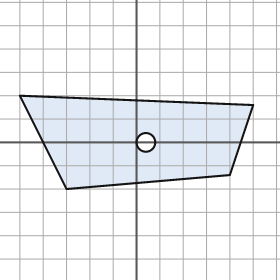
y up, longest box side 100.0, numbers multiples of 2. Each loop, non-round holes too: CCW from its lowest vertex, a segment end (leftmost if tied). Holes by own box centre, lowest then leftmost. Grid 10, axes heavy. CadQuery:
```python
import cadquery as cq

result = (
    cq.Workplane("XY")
    .moveTo(-30.0, -20.0)
    .lineTo(40.0, -14.0)
    .lineTo(50.0, 16.0)
    .lineTo(-50.0, 20.0)
    .close()
    .moveTo(4.0, 0.0)
    .circle(4.0)
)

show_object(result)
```